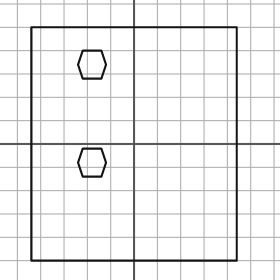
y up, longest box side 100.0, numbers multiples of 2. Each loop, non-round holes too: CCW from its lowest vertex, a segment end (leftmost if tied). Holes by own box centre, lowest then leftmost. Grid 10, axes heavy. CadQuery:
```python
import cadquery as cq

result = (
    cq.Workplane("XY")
    .moveTo(-44.0, -50.0)
    .lineTo(44.0, -50.0)
    .lineTo(44.0, 50.0)
    .lineTo(-44.0, 50.0)
    .close()
    .moveTo(-22.0, -14.0)
    .lineTo(-14.0, -14.0)
    .lineTo(-12.0, -8.0)
    .lineTo(-14.0, -2.0)
    .lineTo(-22.0, -2.0)
    .lineTo(-24.0, -8.0)
    .close()
    .moveTo(-22.0, 28.0)
    .lineTo(-14.0, 28.0)
    .lineTo(-12.0, 34.0)
    .lineTo(-14.0, 40.0)
    .lineTo(-22.0, 40.0)
    .lineTo(-24.0, 34.0)
    .close()
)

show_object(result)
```